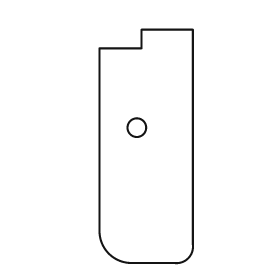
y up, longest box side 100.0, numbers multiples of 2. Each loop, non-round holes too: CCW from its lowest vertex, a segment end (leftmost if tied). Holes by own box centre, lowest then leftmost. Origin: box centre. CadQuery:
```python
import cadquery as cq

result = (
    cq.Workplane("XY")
    .moveTo(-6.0, -50.0)
    .lineTo(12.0, -50.0)
    .threePointArc((18.0, -48.0), (20.0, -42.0))
    .lineTo(20.0, 50.0)
    .lineTo(-2.0, 50.0)
    .lineTo(-2.0, 42.0)
    .lineTo(-20.0, 42.0)
    .lineTo(-20.0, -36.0)
    .threePointArc((-16.0, -46.0), (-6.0, -50.0))
    .close()
    .moveTo(-4.0, 8.0)
    .circle(4.0)
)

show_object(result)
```